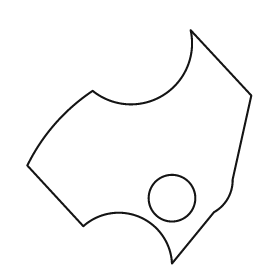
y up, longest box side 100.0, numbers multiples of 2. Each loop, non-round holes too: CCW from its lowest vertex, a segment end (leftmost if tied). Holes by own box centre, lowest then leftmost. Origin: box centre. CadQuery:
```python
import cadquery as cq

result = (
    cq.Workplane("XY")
    .moveTo(14.0, -50.0)
    .lineTo(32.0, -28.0)
    .threePointArc((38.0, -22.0), (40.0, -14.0))
    .lineTo(48.0, 22.0)
    .lineTo(22.0, 50.0)
    .threePointArc((10.0, 22.0), (-20.0, 24.0))
    .threePointArc((-36.0, 10.0), (-48.0, -8.0))
    .lineTo(-24.0, -34.0)
    .threePointArc((0.0, -30.0), (14.0, -50.0))
    .close()
    .moveTo(14.0, -22.0)
    .circle(10.0)
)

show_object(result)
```